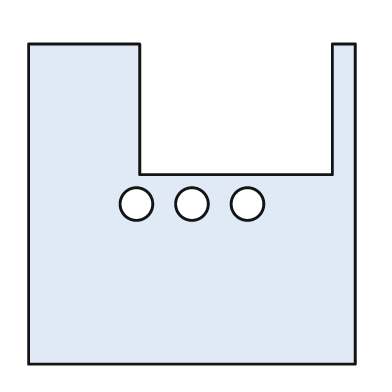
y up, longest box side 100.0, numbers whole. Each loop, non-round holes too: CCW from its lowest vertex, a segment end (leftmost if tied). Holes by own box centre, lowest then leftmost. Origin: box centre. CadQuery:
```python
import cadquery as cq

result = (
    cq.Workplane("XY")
    .moveTo(-50.0, -49.0)
    .lineTo(50.0, -49.0)
    .lineTo(50.0, 49.0)
    .lineTo(43.0, 49.0)
    .lineTo(43.0, 9.0)
    .lineTo(-16.0, 9.0)
    .lineTo(-16.0, 49.0)
    .lineTo(-50.0, 49.0)
    .close()
    .moveTo(-17.0, 0.0)
    .circle(5.0)
    .moveTo(0.0, 0.0)
    .circle(5.0)
    .moveTo(17.0, 0.0)
    .circle(5.0)
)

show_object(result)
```